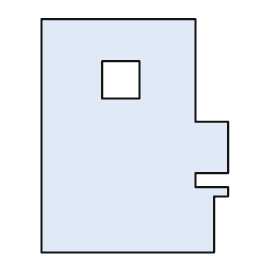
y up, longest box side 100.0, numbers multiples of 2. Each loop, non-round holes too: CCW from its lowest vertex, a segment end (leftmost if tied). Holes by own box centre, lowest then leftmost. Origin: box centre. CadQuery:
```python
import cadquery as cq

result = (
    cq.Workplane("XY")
    .moveTo(-40.0, -50.0)
    .lineTo(34.0, -50.0)
    .lineTo(34.0, -26.0)
    .lineTo(40.0, -26.0)
    .lineTo(40.0, -22.0)
    .lineTo(26.0, -22.0)
    .lineTo(26.0, -16.0)
    .lineTo(40.0, -16.0)
    .lineTo(40.0, 6.0)
    .lineTo(26.0, 6.0)
    .lineTo(26.0, 50.0)
    .lineTo(-40.0, 50.0)
    .close()
    .moveTo(-14.0, 16.0)
    .lineTo(2.0, 16.0)
    .lineTo(2.0, 32.0)
    .lineTo(-14.0, 32.0)
    .close()
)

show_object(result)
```